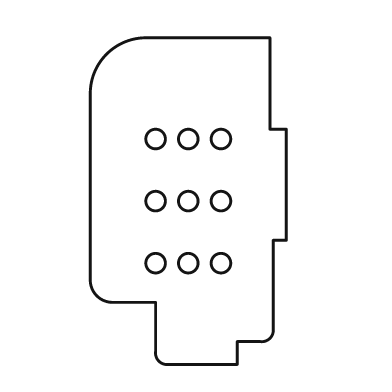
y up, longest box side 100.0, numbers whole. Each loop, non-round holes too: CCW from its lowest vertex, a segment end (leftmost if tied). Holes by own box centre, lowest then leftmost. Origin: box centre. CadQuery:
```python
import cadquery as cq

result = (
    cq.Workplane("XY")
    .moveTo(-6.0, -50.0)
    .lineTo(15.0, -50.0)
    .lineTo(15.0, -43.0)
    .lineTo(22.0, -43.0)
    .threePointArc((25.0, -42.0), (26.0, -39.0))
    .lineTo(26.0, -12.0)
    .lineTo(30.0, -12.0)
    .lineTo(30.0, 22.0)
    .lineTo(25.0, 22.0)
    .lineTo(25.0, 50.0)
    .lineTo(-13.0, 50.0)
    .threePointArc((-25.0, 45.0), (-30.0, 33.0))
    .lineTo(-30.0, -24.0)
    .threePointArc((-28.0, -29.0), (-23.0, -31.0))
    .lineTo(-10.0, -31.0)
    .lineTo(-10.0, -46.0)
    .threePointArc((-9.0, -49.0), (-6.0, -50.0))
    .close()
    .moveTo(-10.0, -19.0)
    .circle(3.0)
    .moveTo(0.0, -19.0)
    .circle(3.0)
    .moveTo(10.0, -19.0)
    .circle(3.0)
    .moveTo(-10.0, 0.0)
    .circle(3.0)
    .moveTo(0.0, 0.0)
    .circle(3.0)
    .moveTo(10.0, 0.0)
    .circle(3.0)
    .moveTo(-10.0, 19.0)
    .circle(3.0)
    .moveTo(0.0, 19.0)
    .circle(3.0)
    .moveTo(10.0, 19.0)
    .circle(3.0)
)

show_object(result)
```